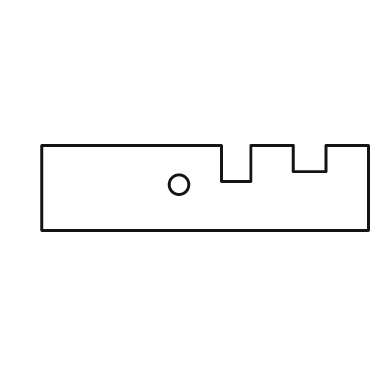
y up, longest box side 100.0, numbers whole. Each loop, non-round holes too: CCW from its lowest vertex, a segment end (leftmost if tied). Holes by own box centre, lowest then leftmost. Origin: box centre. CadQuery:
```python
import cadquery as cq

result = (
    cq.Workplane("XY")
    .moveTo(-50.0, -13.0)
    .lineTo(50.0, -13.0)
    .lineTo(50.0, 13.0)
    .lineTo(37.0, 13.0)
    .lineTo(37.0, 5.0)
    .lineTo(27.0, 5.0)
    .lineTo(27.0, 13.0)
    .lineTo(14.0, 13.0)
    .lineTo(14.0, 2.0)
    .lineTo(5.0, 2.0)
    .lineTo(5.0, 13.0)
    .lineTo(-50.0, 13.0)
    .close()
    .moveTo(-8.0, 1.0)
    .circle(3.0)
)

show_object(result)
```